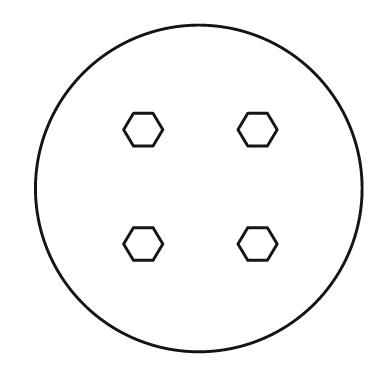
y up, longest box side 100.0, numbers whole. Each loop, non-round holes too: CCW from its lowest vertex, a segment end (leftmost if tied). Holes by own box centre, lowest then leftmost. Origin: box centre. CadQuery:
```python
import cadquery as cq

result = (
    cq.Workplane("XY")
    .moveTo(0.0, 0.0)
    .circle(50.0)
    .moveTo(-20.0, -22.0)
    .lineTo(-14.0, -22.0)
    .lineTo(-11.0, -17.0)
    .lineTo(-14.0, -12.0)
    .lineTo(-20.0, -12.0)
    .lineTo(-23.0, -17.0)
    .close()
    .moveTo(15.0, -22.0)
    .lineTo(21.0, -22.0)
    .lineTo(24.0, -17.0)
    .lineTo(21.0, -12.0)
    .lineTo(15.0, -12.0)
    .lineTo(12.0, -17.0)
    .close()
    .moveTo(-20.0, 13.0)
    .lineTo(-14.0, 13.0)
    .lineTo(-11.0, 18.0)
    .lineTo(-14.0, 23.0)
    .lineTo(-20.0, 23.0)
    .lineTo(-23.0, 18.0)
    .close()
    .moveTo(15.0, 13.0)
    .lineTo(21.0, 13.0)
    .lineTo(24.0, 18.0)
    .lineTo(21.0, 23.0)
    .lineTo(15.0, 23.0)
    .lineTo(12.0, 18.0)
    .close()
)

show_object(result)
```